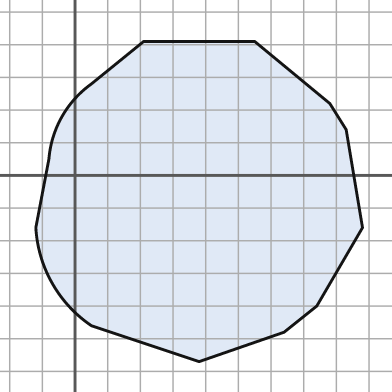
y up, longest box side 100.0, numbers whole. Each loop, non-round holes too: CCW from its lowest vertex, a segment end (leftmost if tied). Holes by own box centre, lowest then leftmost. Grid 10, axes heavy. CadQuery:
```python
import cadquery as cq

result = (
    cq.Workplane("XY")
    .moveTo(38.0, -57.0)
    .lineTo(64.0, -48.0)
    .lineTo(74.0, -40.0)
    .lineTo(88.0, -16.0)
    .lineTo(83.0, 14.0)
    .lineTo(78.0, 22.0)
    .lineTo(55.0, 41.0)
    .lineTo(21.0, 41.0)
    .lineTo(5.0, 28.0)
    .threePointArc((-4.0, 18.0), (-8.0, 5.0))
    .lineTo(-12.0, -16.0)
    .threePointArc((-7.0, -33.0), (5.0, -46.0))
    .close()
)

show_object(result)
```